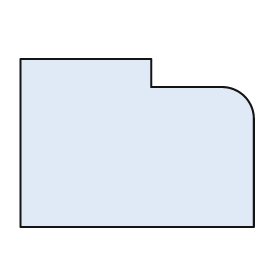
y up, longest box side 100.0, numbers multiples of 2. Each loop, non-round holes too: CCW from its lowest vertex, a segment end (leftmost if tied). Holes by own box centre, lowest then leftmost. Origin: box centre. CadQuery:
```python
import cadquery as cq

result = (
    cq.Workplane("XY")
    .moveTo(-50.0, -36.0)
    .lineTo(50.0, -36.0)
    .lineTo(50.0, 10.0)
    .threePointArc((46.0, 20.0), (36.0, 24.0))
    .lineTo(6.0, 24.0)
    .lineTo(6.0, 36.0)
    .lineTo(-50.0, 36.0)
    .close()
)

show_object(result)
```